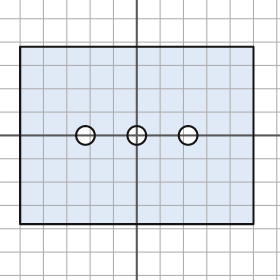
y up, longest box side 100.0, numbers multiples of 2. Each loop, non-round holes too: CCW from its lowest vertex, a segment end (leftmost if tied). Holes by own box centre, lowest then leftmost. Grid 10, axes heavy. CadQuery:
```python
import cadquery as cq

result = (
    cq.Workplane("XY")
    .moveTo(-50.0, -38.0)
    .lineTo(50.0, -38.0)
    .lineTo(50.0, 38.0)
    .lineTo(-50.0, 38.0)
    .close()
    .moveTo(-22.0, 0.0)
    .circle(4.0)
    .moveTo(0.0, 0.0)
    .circle(4.0)
    .moveTo(22.0, 0.0)
    .circle(4.0)
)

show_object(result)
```